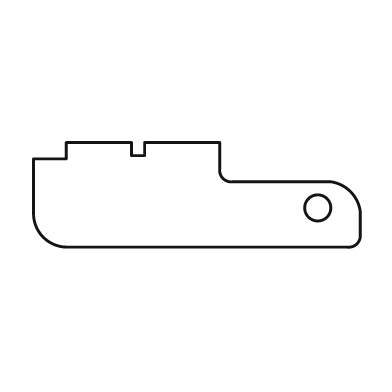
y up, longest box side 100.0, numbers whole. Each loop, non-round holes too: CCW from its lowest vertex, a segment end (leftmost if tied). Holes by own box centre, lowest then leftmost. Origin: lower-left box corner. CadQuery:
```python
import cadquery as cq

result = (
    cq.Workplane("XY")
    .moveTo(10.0, 0.0)
    .lineTo(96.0, 0.0)
    .threePointArc((99.0, 1.0), (100.0, 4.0))
    .lineTo(100.0, 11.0)
    .threePointArc((97.0, 17.0), (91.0, 20.0))
    .lineTo(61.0, 20.0)
    .threePointArc((58.0, 21.0), (57.0, 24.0))
    .lineTo(57.0, 32.0)
    .lineTo(34.0, 32.0)
    .lineTo(34.0, 28.0)
    .lineTo(30.0, 28.0)
    .lineTo(30.0, 32.0)
    .lineTo(10.0, 32.0)
    .lineTo(10.0, 27.0)
    .lineTo(0.0, 27.0)
    .lineTo(0.0, 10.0)
    .threePointArc((3.0, 3.0), (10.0, 0.0))
    .close()
    .moveTo(87.0, 12.0)
    .circle(4.0)
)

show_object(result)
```